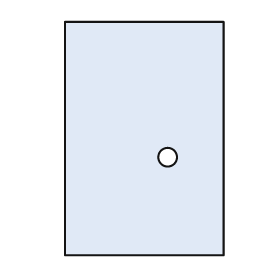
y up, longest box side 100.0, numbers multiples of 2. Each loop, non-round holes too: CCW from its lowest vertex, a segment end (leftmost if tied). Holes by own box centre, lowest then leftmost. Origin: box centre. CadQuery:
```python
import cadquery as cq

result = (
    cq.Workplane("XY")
    .moveTo(-34.0, -50.0)
    .lineTo(34.0, -50.0)
    .lineTo(34.0, 50.0)
    .lineTo(-34.0, 50.0)
    .close()
    .moveTo(10.0, -8.0)
    .circle(4.0)
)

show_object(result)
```